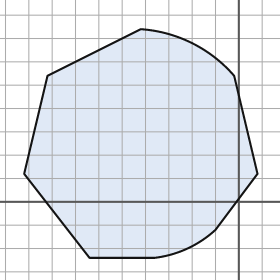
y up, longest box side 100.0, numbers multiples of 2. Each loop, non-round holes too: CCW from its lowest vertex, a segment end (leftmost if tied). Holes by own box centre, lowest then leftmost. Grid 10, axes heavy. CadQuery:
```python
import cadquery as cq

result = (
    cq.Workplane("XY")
    .moveTo(-64.0, -24.0)
    .lineTo(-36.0, -24.0)
    .threePointArc((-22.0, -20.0), (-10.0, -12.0))
    .lineTo(8.0, 12.0)
    .lineTo(-2.0, 54.0)
    .threePointArc((-20.0, 68.0), (-42.0, 74.0))
    .lineTo(-82.0, 54.0)
    .lineTo(-92.0, 12.0)
    .close()
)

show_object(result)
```